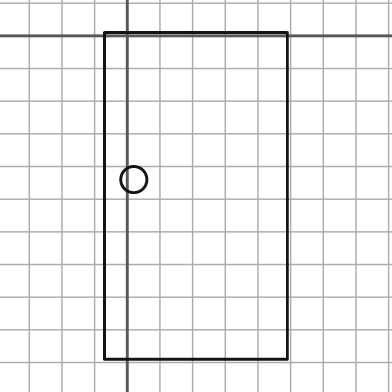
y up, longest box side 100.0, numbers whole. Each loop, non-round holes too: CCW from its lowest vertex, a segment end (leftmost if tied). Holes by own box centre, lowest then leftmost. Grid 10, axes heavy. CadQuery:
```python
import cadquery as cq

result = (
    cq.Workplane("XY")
    .moveTo(-7.0, -99.0)
    .lineTo(49.0, -99.0)
    .lineTo(49.0, 1.0)
    .lineTo(-7.0, 1.0)
    .close()
    .moveTo(2.0, -44.0)
    .circle(4.0)
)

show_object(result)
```